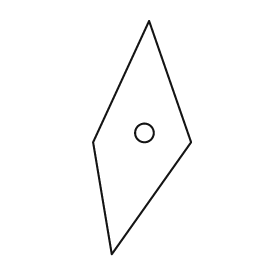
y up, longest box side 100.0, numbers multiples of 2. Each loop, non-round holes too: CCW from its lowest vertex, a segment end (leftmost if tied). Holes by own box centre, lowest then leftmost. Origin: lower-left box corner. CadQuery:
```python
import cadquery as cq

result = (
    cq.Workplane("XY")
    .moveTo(8.0, 0.0)
    .lineTo(42.0, 48.0)
    .lineTo(24.0, 100.0)
    .lineTo(0.0, 48.0)
    .close()
    .moveTo(22.0, 52.0)
    .circle(4.0)
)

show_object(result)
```